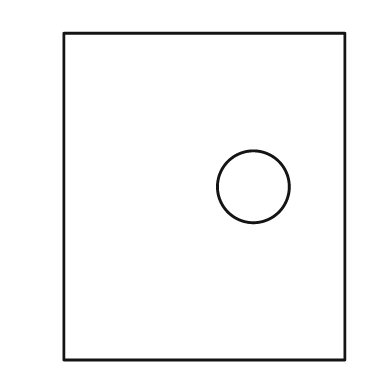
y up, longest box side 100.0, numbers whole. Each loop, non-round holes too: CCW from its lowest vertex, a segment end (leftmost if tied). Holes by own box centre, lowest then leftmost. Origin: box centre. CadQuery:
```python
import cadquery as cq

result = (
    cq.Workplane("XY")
    .moveTo(-43.0, -50.0)
    .lineTo(43.0, -50.0)
    .lineTo(43.0, 50.0)
    .lineTo(-43.0, 50.0)
    .close()
    .moveTo(15.0, 3.0)
    .circle(11.0)
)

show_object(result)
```